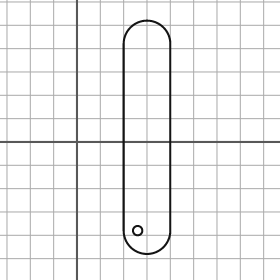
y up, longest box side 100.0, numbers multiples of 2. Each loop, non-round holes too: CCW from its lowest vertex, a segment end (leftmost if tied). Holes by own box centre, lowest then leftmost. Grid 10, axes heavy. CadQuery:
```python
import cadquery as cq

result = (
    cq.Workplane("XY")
    .moveTo(20.0, -38.0)
    .threePointArc((30.0, -48.0), (40.0, -38.0))
    .lineTo(40.0, 42.0)
    .threePointArc((30.0, 52.0), (20.0, 42.0))
    .close()
    .moveTo(26.0, -38.0)
    .circle(2.0)
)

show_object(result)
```